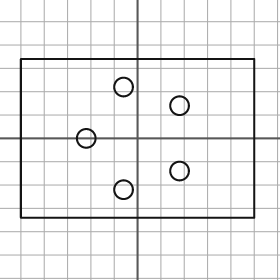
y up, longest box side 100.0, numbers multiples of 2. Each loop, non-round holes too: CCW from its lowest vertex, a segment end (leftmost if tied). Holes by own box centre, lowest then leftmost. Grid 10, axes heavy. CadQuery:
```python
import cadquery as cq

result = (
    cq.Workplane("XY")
    .moveTo(-50.0, -34.0)
    .lineTo(50.0, -34.0)
    .lineTo(50.0, 34.0)
    .lineTo(-50.0, 34.0)
    .close()
    .moveTo(-6.0, -22.0)
    .circle(4.0)
    .moveTo(18.0, -14.0)
    .circle(4.0)
    .moveTo(-22.0, 0.0)
    .circle(4.0)
    .moveTo(18.0, 14.0)
    .circle(4.0)
    .moveTo(-6.0, 22.0)
    .circle(4.0)
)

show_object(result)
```